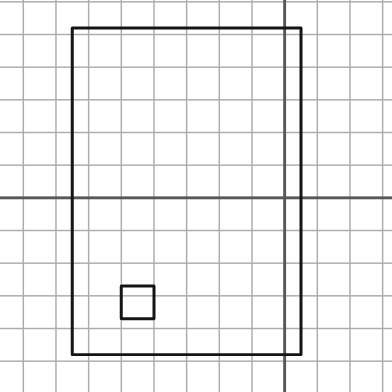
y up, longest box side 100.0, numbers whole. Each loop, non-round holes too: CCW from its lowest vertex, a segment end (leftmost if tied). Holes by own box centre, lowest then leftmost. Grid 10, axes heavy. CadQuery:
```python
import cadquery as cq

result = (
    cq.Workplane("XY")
    .moveTo(-65.0, -48.0)
    .lineTo(5.0, -48.0)
    .lineTo(5.0, 52.0)
    .lineTo(-65.0, 52.0)
    .close()
    .moveTo(-50.0, -37.0)
    .lineTo(-40.0, -37.0)
    .lineTo(-40.0, -27.0)
    .lineTo(-50.0, -27.0)
    .close()
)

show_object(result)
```